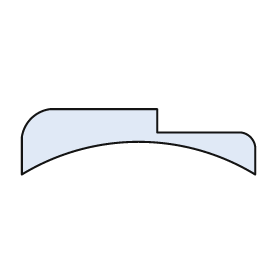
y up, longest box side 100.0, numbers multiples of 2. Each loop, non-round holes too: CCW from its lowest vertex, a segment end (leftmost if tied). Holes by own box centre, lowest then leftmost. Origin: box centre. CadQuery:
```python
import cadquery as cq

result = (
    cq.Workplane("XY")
    .moveTo(-50.0, -14.0)
    .threePointArc((0.0, 0.0), (50.0, -14.0))
    .lineTo(50.0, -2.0)
    .threePointArc((48.0, 2.0), (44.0, 4.0))
    .lineTo(8.0, 4.0)
    .lineTo(8.0, 14.0)
    .lineTo(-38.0, 14.0)
    .threePointArc((-46.0, 10.0), (-50.0, 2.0))
    .close()
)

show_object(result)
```